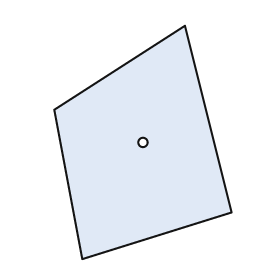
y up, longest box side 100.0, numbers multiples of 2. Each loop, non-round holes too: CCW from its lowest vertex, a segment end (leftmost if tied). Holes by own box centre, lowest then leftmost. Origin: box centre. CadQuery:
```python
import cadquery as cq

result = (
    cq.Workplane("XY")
    .moveTo(-26.0, -50.0)
    .lineTo(38.0, -30.0)
    .lineTo(18.0, 50.0)
    .lineTo(-38.0, 14.0)
    .close()
    .moveTo(0.0, 0.0)
    .circle(2.0)
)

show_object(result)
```